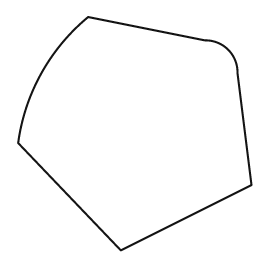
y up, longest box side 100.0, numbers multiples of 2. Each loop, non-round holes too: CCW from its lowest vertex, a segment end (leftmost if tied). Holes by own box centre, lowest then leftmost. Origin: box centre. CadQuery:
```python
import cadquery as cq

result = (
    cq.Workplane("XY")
    .moveTo(-6.0, -50.0)
    .lineTo(50.0, -22.0)
    .lineTo(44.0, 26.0)
    .threePointArc((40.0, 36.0), (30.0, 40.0))
    .lineTo(-20.0, 50.0)
    .threePointArc((-40.0, 26.0), (-50.0, -4.0))
    .close()
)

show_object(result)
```